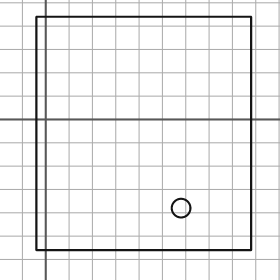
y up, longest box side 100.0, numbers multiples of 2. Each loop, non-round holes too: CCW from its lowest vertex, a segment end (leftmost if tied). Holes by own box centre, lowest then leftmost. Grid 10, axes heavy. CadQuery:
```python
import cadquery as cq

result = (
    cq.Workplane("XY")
    .moveTo(-4.0, -56.0)
    .lineTo(88.0, -56.0)
    .lineTo(88.0, 44.0)
    .lineTo(-4.0, 44.0)
    .close()
    .moveTo(58.0, -38.0)
    .circle(4.0)
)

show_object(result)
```